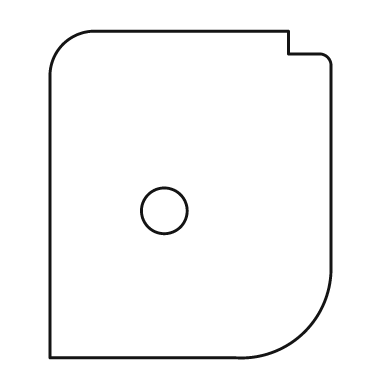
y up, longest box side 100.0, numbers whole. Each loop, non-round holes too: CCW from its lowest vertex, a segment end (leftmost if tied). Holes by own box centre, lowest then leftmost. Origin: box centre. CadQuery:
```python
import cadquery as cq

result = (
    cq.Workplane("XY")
    .moveTo(-43.0, -50.0)
    .lineTo(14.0, -50.0)
    .threePointArc((35.0, -42.0), (43.0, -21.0))
    .lineTo(43.0, 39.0)
    .threePointArc((42.0, 42.0), (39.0, 43.0))
    .lineTo(30.0, 43.0)
    .lineTo(30.0, 50.0)
    .lineTo(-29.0, 50.0)
    .threePointArc((-39.0, 46.0), (-43.0, 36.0))
    .close()
    .moveTo(-8.0, -5.0)
    .circle(7.0)
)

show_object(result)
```